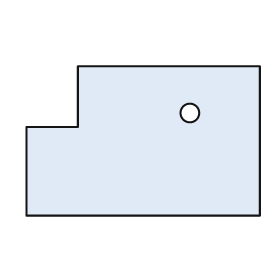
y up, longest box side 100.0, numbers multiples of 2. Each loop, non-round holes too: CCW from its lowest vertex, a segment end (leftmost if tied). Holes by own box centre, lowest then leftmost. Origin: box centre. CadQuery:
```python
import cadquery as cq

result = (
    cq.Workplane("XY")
    .moveTo(-50.0, -32.0)
    .lineTo(50.0, -32.0)
    .lineTo(50.0, 32.0)
    .lineTo(-28.0, 32.0)
    .lineTo(-28.0, 6.0)
    .lineTo(-50.0, 6.0)
    .close()
    .moveTo(20.0, 12.0)
    .circle(4.0)
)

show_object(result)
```